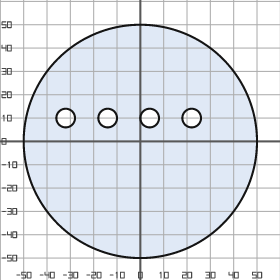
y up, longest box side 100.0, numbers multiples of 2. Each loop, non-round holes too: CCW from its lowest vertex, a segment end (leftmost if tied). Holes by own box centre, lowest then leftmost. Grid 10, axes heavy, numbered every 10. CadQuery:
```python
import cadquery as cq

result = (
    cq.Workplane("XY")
    .moveTo(0.0, 0.0)
    .circle(50.0)
    .moveTo(-32.0, 10.0)
    .circle(4.0)
    .moveTo(-14.0, 10.0)
    .circle(4.0)
    .moveTo(4.0, 10.0)
    .circle(4.0)
    .moveTo(22.0, 10.0)
    .circle(4.0)
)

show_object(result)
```